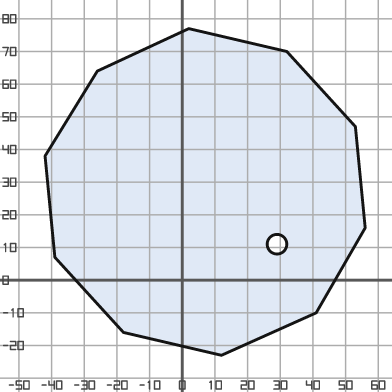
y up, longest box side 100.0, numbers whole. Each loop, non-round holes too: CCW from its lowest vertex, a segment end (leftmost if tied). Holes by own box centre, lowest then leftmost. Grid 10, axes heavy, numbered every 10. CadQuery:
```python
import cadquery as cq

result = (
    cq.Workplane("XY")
    .moveTo(12.0, -23.0)
    .lineTo(41.0, -10.0)
    .lineTo(56.0, 16.0)
    .lineTo(53.0, 47.0)
    .lineTo(32.0, 70.0)
    .lineTo(2.0, 77.0)
    .lineTo(-26.0, 64.0)
    .lineTo(-42.0, 38.0)
    .lineTo(-39.0, 7.0)
    .lineTo(-18.0, -16.0)
    .close()
    .moveTo(29.0, 11.0)
    .circle(3.0)
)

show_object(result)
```